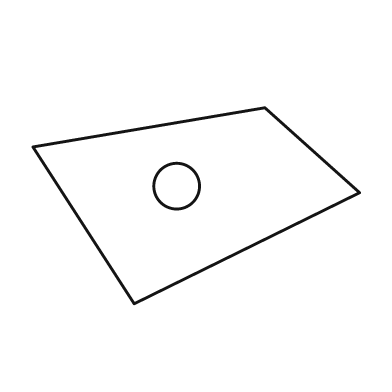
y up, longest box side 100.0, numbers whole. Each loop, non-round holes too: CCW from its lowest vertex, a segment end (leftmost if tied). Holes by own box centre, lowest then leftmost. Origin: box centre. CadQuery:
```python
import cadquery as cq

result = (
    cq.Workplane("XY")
    .moveTo(-19.0, -30.0)
    .lineTo(50.0, 4.0)
    .lineTo(21.0, 30.0)
    .lineTo(-50.0, 18.0)
    .close()
    .moveTo(-6.0, 6.0)
    .circle(7.0)
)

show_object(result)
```